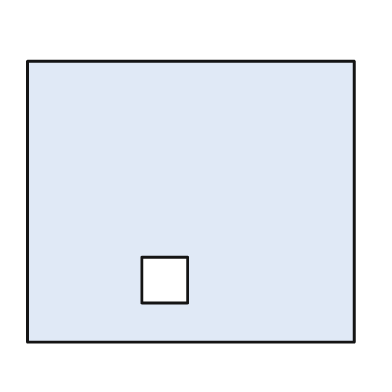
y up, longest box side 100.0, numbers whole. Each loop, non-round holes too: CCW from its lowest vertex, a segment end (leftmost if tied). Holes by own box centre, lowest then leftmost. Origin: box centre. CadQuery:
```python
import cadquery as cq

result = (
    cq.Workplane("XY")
    .moveTo(-50.0, -43.0)
    .lineTo(50.0, -43.0)
    .lineTo(50.0, 43.0)
    .lineTo(-50.0, 43.0)
    .close()
    .moveTo(-15.0, -31.0)
    .lineTo(-1.0, -31.0)
    .lineTo(-1.0, -17.0)
    .lineTo(-15.0, -17.0)
    .close()
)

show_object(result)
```